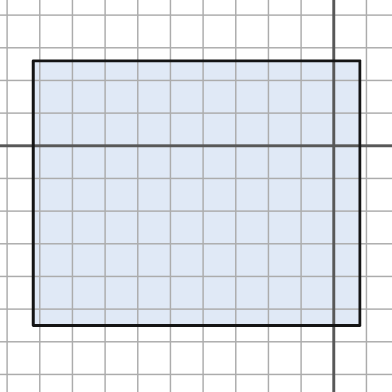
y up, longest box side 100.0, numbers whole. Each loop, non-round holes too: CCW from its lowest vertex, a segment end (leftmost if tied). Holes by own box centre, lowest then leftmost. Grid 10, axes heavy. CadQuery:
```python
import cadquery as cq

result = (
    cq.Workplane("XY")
    .moveTo(-92.0, -55.0)
    .lineTo(8.0, -55.0)
    .lineTo(8.0, 26.0)
    .lineTo(-92.0, 26.0)
    .close()
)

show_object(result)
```